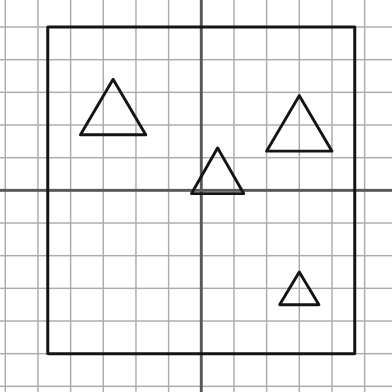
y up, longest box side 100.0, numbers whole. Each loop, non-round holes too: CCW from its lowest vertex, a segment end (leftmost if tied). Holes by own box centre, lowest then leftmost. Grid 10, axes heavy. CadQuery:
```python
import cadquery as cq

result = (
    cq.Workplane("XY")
    .moveTo(-47.0, -50.0)
    .lineTo(47.0, -50.0)
    .lineTo(47.0, 50.0)
    .lineTo(-47.0, 50.0)
    .close()
    .moveTo(24.0, -35.0)
    .lineTo(36.0, -35.0)
    .lineTo(30.0, -25.0)
    .close()
    .moveTo(-3.0, -1.0)
    .lineTo(13.0, -1.0)
    .lineTo(5.0, 13.0)
    .close()
    .moveTo(20.0, 12.0)
    .lineTo(40.0, 12.0)
    .lineTo(30.0, 29.0)
    .close()
    .moveTo(-37.0, 17.0)
    .lineTo(-17.0, 17.0)
    .lineTo(-27.0, 34.0)
    .close()
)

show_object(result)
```